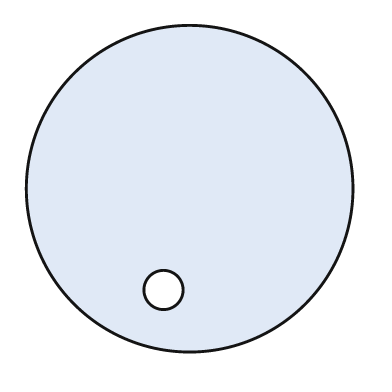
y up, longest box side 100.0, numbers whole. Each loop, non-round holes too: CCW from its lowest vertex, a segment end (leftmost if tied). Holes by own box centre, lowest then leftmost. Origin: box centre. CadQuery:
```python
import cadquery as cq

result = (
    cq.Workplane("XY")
    .moveTo(0.0, 0.0)
    .circle(50.0)
    .moveTo(-8.0, -31.0)
    .circle(6.0)
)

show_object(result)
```